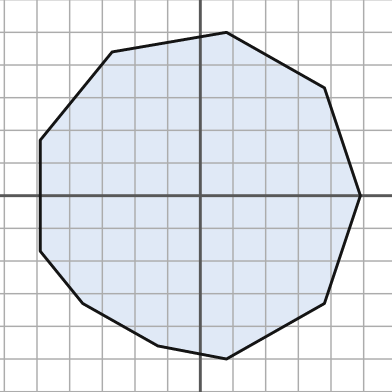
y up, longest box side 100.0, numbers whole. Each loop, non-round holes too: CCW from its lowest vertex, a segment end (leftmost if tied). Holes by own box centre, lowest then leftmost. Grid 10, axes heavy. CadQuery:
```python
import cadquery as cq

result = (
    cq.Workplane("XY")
    .moveTo(8.0, -50.0)
    .lineTo(38.0, -33.0)
    .lineTo(49.0, 0.0)
    .lineTo(38.0, 33.0)
    .lineTo(8.0, 50.0)
    .lineTo(-27.0, 44.0)
    .lineTo(-49.0, 17.0)
    .lineTo(-49.0, -17.0)
    .lineTo(-36.0, -33.0)
    .lineTo(-13.0, -46.0)
    .close()
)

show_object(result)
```